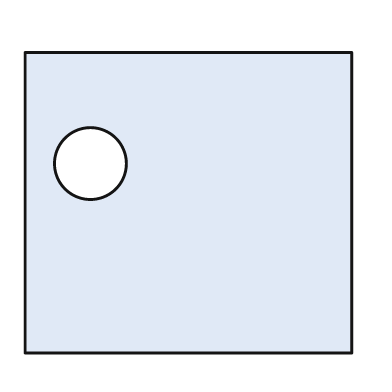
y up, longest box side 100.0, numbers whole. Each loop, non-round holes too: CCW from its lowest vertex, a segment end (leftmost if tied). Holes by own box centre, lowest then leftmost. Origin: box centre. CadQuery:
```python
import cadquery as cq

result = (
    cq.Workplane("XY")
    .moveTo(-50.0, -46.0)
    .lineTo(50.0, -46.0)
    .lineTo(50.0, 46.0)
    .lineTo(-50.0, 46.0)
    .close()
    .moveTo(-30.0, 12.0)
    .circle(11.0)
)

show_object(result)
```